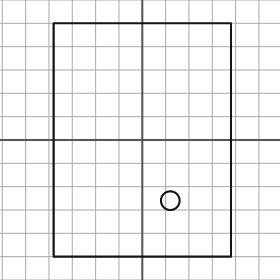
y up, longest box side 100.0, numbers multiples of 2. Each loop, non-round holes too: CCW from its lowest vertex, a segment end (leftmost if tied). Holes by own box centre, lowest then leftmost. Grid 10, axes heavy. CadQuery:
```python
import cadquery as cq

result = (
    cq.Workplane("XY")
    .moveTo(-38.0, -50.0)
    .lineTo(38.0, -50.0)
    .lineTo(38.0, 50.0)
    .lineTo(-38.0, 50.0)
    .close()
    .moveTo(12.0, -26.0)
    .circle(4.0)
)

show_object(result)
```